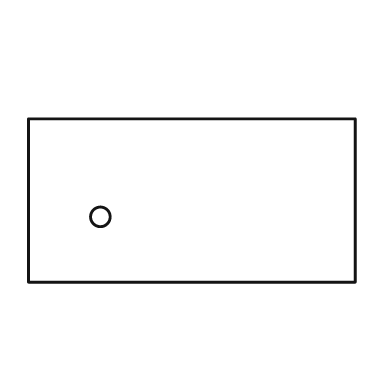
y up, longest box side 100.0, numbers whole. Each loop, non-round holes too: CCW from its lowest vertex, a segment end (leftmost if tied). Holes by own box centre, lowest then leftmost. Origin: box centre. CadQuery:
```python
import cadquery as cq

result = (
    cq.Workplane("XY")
    .moveTo(-50.0, -25.0)
    .lineTo(50.0, -25.0)
    .lineTo(50.0, 25.0)
    .lineTo(-50.0, 25.0)
    .close()
    .moveTo(-28.0, -5.0)
    .circle(3.0)
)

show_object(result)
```